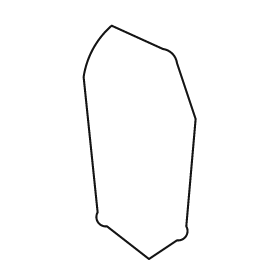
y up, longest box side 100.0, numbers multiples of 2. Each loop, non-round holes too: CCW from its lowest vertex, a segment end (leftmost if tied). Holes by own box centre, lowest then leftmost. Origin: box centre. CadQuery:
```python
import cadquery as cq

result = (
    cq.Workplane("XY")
    .moveTo(4.0, -50.0)
    .lineTo(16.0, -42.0)
    .threePointArc((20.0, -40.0), (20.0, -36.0))
    .lineTo(24.0, 10.0)
    .lineTo(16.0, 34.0)
    .threePointArc((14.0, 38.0), (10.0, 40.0))
    .lineTo(-12.0, 50.0)
    .threePointArc((-20.0, 40.0), (-24.0, 28.0))
    .lineTo(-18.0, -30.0)
    .threePointArc((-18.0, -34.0), (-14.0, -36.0))
    .close()
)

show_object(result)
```